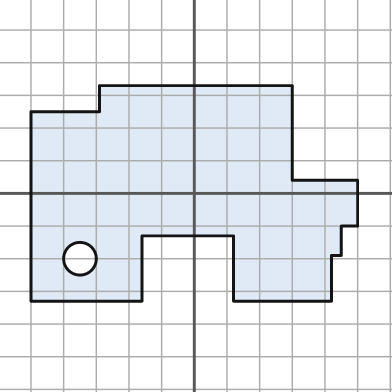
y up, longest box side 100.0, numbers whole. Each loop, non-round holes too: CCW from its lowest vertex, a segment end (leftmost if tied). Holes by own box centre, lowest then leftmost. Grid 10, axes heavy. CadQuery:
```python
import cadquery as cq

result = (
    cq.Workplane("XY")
    .moveTo(-50.0, -33.0)
    .lineTo(-16.0, -33.0)
    .lineTo(-16.0, -13.0)
    .lineTo(12.0, -13.0)
    .lineTo(12.0, -33.0)
    .lineTo(42.0, -33.0)
    .lineTo(42.0, -19.0)
    .lineTo(45.0, -19.0)
    .lineTo(45.0, -10.0)
    .lineTo(50.0, -10.0)
    .lineTo(50.0, 4.0)
    .lineTo(30.0, 4.0)
    .lineTo(30.0, 33.0)
    .lineTo(-29.0, 33.0)
    .lineTo(-29.0, 25.0)
    .lineTo(-50.0, 25.0)
    .close()
    .moveTo(-35.0, -20.0)
    .circle(5.0)
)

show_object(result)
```